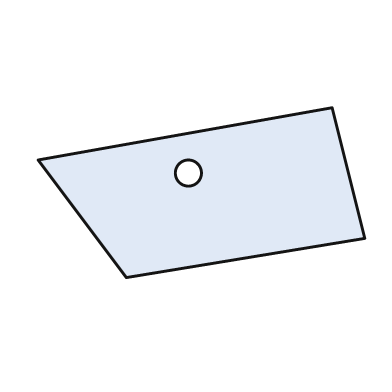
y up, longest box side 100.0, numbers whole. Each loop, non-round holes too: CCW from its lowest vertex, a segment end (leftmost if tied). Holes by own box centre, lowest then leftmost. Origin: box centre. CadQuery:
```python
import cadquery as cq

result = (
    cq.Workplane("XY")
    .moveTo(-23.0, -26.0)
    .lineTo(50.0, -14.0)
    .lineTo(40.0, 26.0)
    .lineTo(-50.0, 10.0)
    .close()
    .moveTo(-4.0, 6.0)
    .circle(4.0)
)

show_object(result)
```